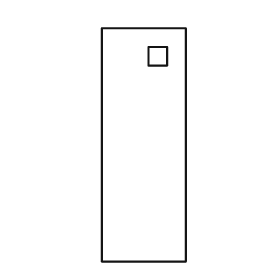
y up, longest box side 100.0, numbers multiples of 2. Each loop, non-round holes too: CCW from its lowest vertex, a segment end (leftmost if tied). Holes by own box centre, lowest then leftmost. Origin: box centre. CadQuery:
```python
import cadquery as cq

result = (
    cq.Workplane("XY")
    .moveTo(-18.0, -50.0)
    .lineTo(18.0, -50.0)
    .lineTo(18.0, 50.0)
    .lineTo(-18.0, 50.0)
    .close()
    .moveTo(2.0, 34.0)
    .lineTo(10.0, 34.0)
    .lineTo(10.0, 42.0)
    .lineTo(2.0, 42.0)
    .close()
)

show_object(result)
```